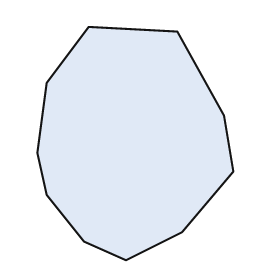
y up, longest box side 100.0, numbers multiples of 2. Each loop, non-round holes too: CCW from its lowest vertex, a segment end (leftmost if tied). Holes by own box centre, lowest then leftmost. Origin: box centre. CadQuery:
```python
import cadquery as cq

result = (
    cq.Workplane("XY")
    .moveTo(-4.0, -50.0)
    .lineTo(20.0, -38.0)
    .lineTo(42.0, -12.0)
    .lineTo(38.0, 12.0)
    .lineTo(18.0, 48.0)
    .lineTo(-20.0, 50.0)
    .lineTo(-38.0, 26.0)
    .lineTo(-42.0, -4.0)
    .lineTo(-38.0, -22.0)
    .lineTo(-22.0, -42.0)
    .close()
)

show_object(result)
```